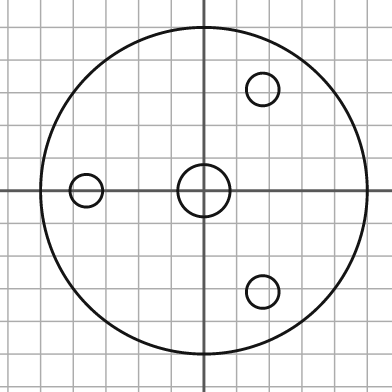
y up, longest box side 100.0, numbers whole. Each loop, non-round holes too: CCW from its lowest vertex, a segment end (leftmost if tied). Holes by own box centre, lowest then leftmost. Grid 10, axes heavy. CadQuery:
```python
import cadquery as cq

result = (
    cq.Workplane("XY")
    .moveTo(0.0, 0.0)
    .circle(50.0)
    .moveTo(18.0, -31.0)
    .circle(5.0)
    .moveTo(-36.0, 0.0)
    .circle(5.0)
    .moveTo(0.0, 0.0)
    .circle(8.0)
    .moveTo(18.0, 31.0)
    .circle(5.0)
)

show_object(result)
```